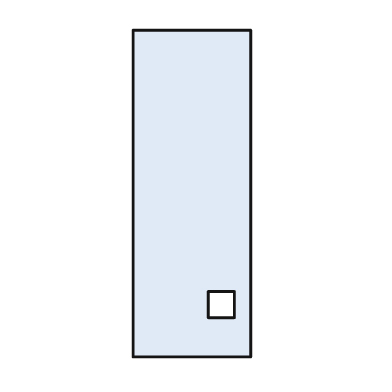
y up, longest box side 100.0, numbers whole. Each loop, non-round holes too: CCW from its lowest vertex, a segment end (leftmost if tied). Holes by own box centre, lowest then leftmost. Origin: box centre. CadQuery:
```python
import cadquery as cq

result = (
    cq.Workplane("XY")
    .moveTo(-18.0, -50.0)
    .lineTo(18.0, -50.0)
    .lineTo(18.0, 50.0)
    .lineTo(-18.0, 50.0)
    .close()
    .moveTo(5.0, -38.0)
    .lineTo(13.0, -38.0)
    .lineTo(13.0, -30.0)
    .lineTo(5.0, -30.0)
    .close()
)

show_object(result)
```